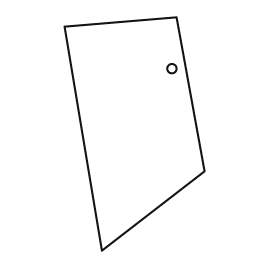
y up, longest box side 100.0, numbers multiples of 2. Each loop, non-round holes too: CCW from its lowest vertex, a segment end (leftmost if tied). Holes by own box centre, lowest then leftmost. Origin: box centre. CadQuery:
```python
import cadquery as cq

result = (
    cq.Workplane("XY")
    .moveTo(-14.0, -50.0)
    .lineTo(30.0, -16.0)
    .lineTo(18.0, 50.0)
    .lineTo(-30.0, 46.0)
    .close()
    .moveTo(16.0, 28.0)
    .circle(2.0)
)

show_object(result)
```